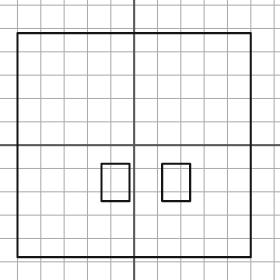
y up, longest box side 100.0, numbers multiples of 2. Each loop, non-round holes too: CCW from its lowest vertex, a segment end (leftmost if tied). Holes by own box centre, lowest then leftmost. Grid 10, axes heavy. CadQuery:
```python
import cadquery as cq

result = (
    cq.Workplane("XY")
    .moveTo(-50.0, -48.0)
    .lineTo(50.0, -48.0)
    .lineTo(50.0, 48.0)
    .lineTo(-50.0, 48.0)
    .close()
    .moveTo(-14.0, -24.0)
    .lineTo(-2.0, -24.0)
    .lineTo(-2.0, -8.0)
    .lineTo(-14.0, -8.0)
    .close()
    .moveTo(12.0, -24.0)
    .lineTo(24.0, -24.0)
    .lineTo(24.0, -8.0)
    .lineTo(12.0, -8.0)
    .close()
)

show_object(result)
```